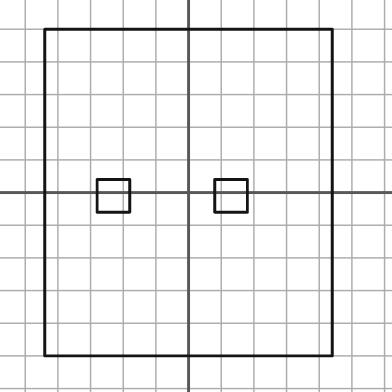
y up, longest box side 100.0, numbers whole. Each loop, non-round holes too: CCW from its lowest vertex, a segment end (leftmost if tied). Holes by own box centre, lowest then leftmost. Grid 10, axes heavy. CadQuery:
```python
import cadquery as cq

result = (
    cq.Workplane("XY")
    .moveTo(-44.0, -50.0)
    .lineTo(44.0, -50.0)
    .lineTo(44.0, 50.0)
    .lineTo(-44.0, 50.0)
    .close()
    .moveTo(-28.0, -6.0)
    .lineTo(-18.0, -6.0)
    .lineTo(-18.0, 4.0)
    .lineTo(-28.0, 4.0)
    .close()
    .moveTo(8.0, -6.0)
    .lineTo(18.0, -6.0)
    .lineTo(18.0, 4.0)
    .lineTo(8.0, 4.0)
    .close()
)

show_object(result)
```